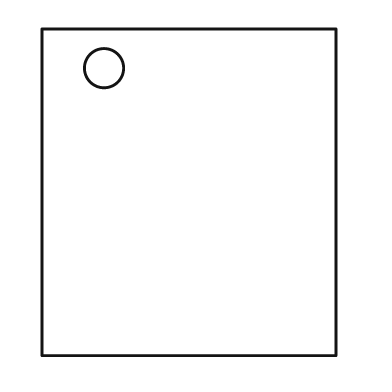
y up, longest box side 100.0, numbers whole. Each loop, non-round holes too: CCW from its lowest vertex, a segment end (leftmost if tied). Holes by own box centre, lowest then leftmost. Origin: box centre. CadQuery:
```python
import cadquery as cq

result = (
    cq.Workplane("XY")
    .moveTo(-45.0, -50.0)
    .lineTo(45.0, -50.0)
    .lineTo(45.0, 50.0)
    .lineTo(-45.0, 50.0)
    .close()
    .moveTo(-26.0, 38.0)
    .circle(6.0)
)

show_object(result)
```